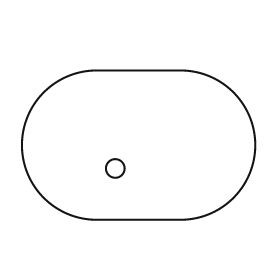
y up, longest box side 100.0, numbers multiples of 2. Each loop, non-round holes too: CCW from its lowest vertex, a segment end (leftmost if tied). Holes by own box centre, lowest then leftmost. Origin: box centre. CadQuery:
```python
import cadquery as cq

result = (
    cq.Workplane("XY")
    .moveTo(-18.0, -32.0)
    .lineTo(18.0, -32.0)
    .threePointArc((50.0, 0.0), (18.0, 32.0))
    .lineTo(-18.0, 32.0)
    .threePointArc((-50.0, 0.0), (-18.0, -32.0))
    .close()
    .moveTo(-10.0, -10.0)
    .circle(4.0)
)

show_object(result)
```